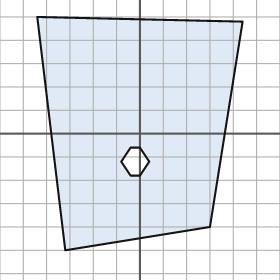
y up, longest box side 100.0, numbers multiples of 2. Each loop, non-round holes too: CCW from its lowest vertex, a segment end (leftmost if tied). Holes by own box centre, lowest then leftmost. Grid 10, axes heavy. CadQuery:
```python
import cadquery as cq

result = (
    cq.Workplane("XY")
    .moveTo(-32.0, -50.0)
    .lineTo(30.0, -40.0)
    .lineTo(44.0, 48.0)
    .lineTo(-44.0, 50.0)
    .close()
    .moveTo(-4.0, -18.0)
    .lineTo(0.0, -18.0)
    .lineTo(4.0, -12.0)
    .lineTo(0.0, -6.0)
    .lineTo(-4.0, -6.0)
    .lineTo(-8.0, -12.0)
    .close()
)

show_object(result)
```